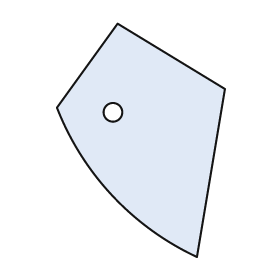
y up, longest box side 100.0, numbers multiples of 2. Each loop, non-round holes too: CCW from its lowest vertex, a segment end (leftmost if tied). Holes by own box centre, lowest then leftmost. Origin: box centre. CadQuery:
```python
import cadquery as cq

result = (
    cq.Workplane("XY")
    .moveTo(24.0, -50.0)
    .lineTo(36.0, 22.0)
    .lineTo(-10.0, 50.0)
    .lineTo(-36.0, 14.0)
    .threePointArc((-12.0, -24.0), (24.0, -50.0))
    .close()
    .moveTo(-12.0, 12.0)
    .circle(4.0)
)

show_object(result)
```